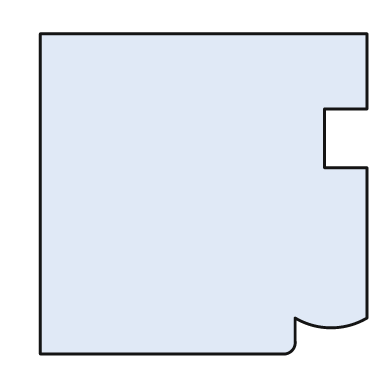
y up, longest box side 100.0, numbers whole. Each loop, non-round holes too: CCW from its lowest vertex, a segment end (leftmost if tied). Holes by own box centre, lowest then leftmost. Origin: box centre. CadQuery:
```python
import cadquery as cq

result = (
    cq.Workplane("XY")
    .moveTo(-50.0, -49.0)
    .lineTo(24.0, -49.0)
    .threePointArc((27.0, -48.0), (28.0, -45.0))
    .lineTo(28.0, -38.0)
    .threePointArc((39.0, -41.0), (50.0, -38.0))
    .lineTo(50.0, 8.0)
    .lineTo(37.0, 8.0)
    .lineTo(37.0, 26.0)
    .lineTo(50.0, 26.0)
    .lineTo(50.0, 49.0)
    .lineTo(-50.0, 49.0)
    .close()
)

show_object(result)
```